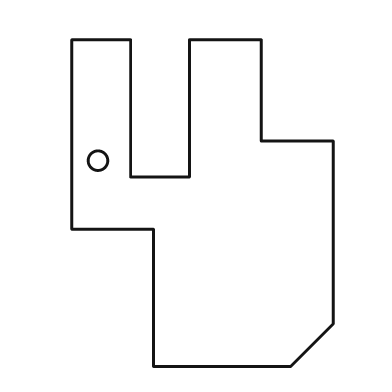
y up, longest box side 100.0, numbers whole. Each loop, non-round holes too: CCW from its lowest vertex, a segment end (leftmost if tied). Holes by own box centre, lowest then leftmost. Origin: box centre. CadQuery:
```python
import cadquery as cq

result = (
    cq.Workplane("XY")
    .moveTo(-15.0, -50.0)
    .lineTo(27.0, -50.0)
    .lineTo(40.0, -37.0)
    .lineTo(40.0, 19.0)
    .lineTo(18.0, 19.0)
    .lineTo(18.0, 50.0)
    .lineTo(-4.0, 50.0)
    .lineTo(-4.0, 8.0)
    .lineTo(-22.0, 8.0)
    .lineTo(-22.0, 50.0)
    .lineTo(-40.0, 50.0)
    .lineTo(-40.0, -8.0)
    .lineTo(-15.0, -8.0)
    .close()
    .moveTo(-32.0, 13.0)
    .circle(3.0)
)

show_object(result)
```